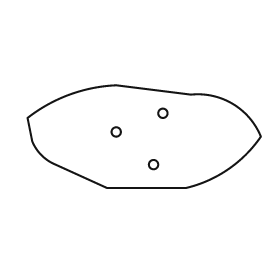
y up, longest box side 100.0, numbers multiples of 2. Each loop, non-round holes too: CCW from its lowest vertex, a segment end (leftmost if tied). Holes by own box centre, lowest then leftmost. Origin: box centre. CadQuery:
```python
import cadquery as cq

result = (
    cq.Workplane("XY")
    .moveTo(-16.0, -22.0)
    .lineTo(18.0, -22.0)
    .threePointArc((36.0, -14.0), (50.0, 0.0))
    .threePointArc((38.0, 14.0), (20.0, 18.0))
    .lineTo(-12.0, 22.0)
    .threePointArc((-32.0, 18.0), (-50.0, 8.0))
    .lineTo(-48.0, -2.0)
    .threePointArc((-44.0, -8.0), (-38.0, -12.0))
    .close()
    .moveTo(4.0, -12.0)
    .circle(2.0)
    .moveTo(-12.0, 2.0)
    .circle(2.0)
    .moveTo(8.0, 10.0)
    .circle(2.0)
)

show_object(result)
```